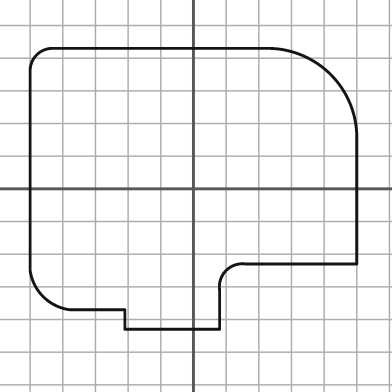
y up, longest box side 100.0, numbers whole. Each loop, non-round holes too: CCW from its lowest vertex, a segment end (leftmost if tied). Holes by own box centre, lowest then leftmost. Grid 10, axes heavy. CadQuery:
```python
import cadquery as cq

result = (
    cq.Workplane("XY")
    .moveTo(-21.0, -43.0)
    .lineTo(8.0, -43.0)
    .lineTo(8.0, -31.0)
    .threePointArc((10.0, -25.0), (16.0, -23.0))
    .lineTo(50.0, -23.0)
    .lineTo(50.0, 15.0)
    .threePointArc((42.0, 35.0), (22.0, 43.0))
    .lineTo(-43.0, 43.0)
    .threePointArc((-48.0, 41.0), (-50.0, 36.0))
    .lineTo(-50.0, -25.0)
    .threePointArc((-46.0, -33.0), (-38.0, -37.0))
    .lineTo(-21.0, -37.0)
    .close()
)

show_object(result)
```